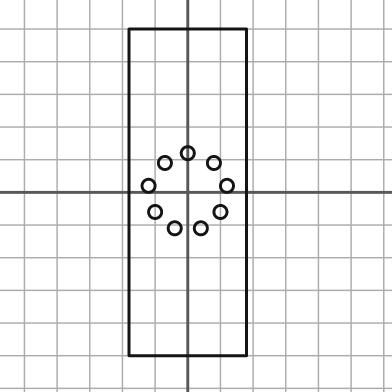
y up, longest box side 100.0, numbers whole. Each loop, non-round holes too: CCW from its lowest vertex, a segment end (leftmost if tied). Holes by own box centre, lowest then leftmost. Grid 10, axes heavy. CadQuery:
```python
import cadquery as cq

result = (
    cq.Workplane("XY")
    .moveTo(-18.0, -50.0)
    .lineTo(18.0, -50.0)
    .lineTo(18.0, 50.0)
    .lineTo(-18.0, 50.0)
    .close()
    .moveTo(-4.0, -11.0)
    .circle(2.0)
    .moveTo(4.0, -11.0)
    .circle(2.0)
    .moveTo(-10.0, -6.0)
    .circle(2.0)
    .moveTo(10.0, -6.0)
    .circle(2.0)
    .moveTo(-12.0, 2.0)
    .circle(2.0)
    .moveTo(12.0, 2.0)
    .circle(2.0)
    .moveTo(-7.0, 9.0)
    .circle(2.0)
    .moveTo(8.0, 9.0)
    .circle(2.0)
    .moveTo(0.0, 12.0)
    .circle(2.0)
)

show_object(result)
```